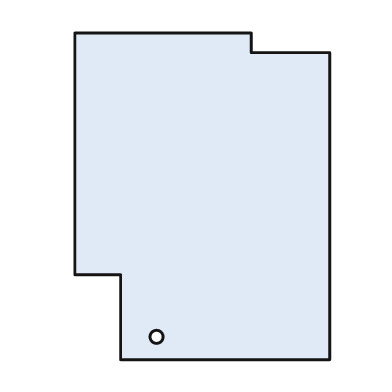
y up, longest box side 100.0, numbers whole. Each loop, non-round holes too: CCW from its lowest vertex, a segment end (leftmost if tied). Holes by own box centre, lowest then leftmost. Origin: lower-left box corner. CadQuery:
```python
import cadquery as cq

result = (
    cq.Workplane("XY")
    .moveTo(14.0, 0.0)
    .lineTo(78.0, 0.0)
    .lineTo(78.0, 94.0)
    .lineTo(54.0, 94.0)
    .lineTo(54.0, 100.0)
    .lineTo(0.0, 100.0)
    .lineTo(0.0, 26.0)
    .lineTo(14.0, 26.0)
    .close()
    .moveTo(25.0, 7.0)
    .circle(2.0)
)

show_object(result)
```